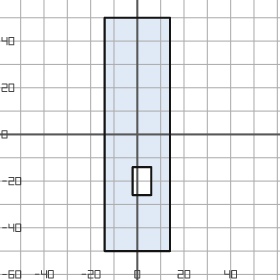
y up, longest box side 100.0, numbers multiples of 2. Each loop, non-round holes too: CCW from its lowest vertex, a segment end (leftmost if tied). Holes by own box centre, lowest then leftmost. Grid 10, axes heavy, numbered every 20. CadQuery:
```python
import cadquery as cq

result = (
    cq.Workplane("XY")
    .moveTo(-14.0, -50.0)
    .lineTo(14.0, -50.0)
    .lineTo(14.0, 50.0)
    .lineTo(-14.0, 50.0)
    .close()
    .moveTo(-2.0, -26.0)
    .lineTo(6.0, -26.0)
    .lineTo(6.0, -14.0)
    .lineTo(-2.0, -14.0)
    .close()
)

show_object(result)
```